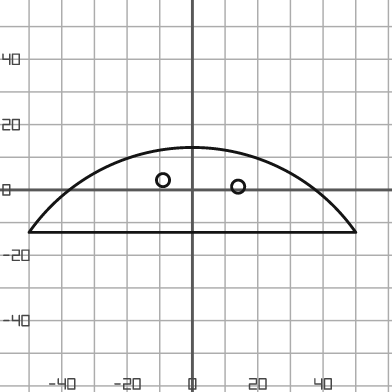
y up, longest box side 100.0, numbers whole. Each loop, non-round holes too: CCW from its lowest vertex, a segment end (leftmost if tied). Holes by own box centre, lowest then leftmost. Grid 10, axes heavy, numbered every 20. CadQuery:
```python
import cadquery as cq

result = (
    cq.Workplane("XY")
    .moveTo(-50.0, -13.0)
    .lineTo(50.0, -13.0)
    .threePointArc((0.0, 13.0), (-50.0, -13.0))
    .close()
    .moveTo(14.0, 1.0)
    .circle(2.0)
    .moveTo(-9.0, 3.0)
    .circle(2.0)
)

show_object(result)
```